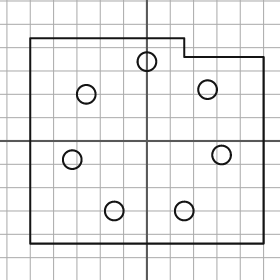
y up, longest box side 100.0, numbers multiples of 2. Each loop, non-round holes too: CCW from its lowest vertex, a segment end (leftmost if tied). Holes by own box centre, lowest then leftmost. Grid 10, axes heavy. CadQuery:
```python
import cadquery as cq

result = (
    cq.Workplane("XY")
    .moveTo(-50.0, -44.0)
    .lineTo(50.0, -44.0)
    .lineTo(50.0, 36.0)
    .lineTo(16.0, 36.0)
    .lineTo(16.0, 44.0)
    .lineTo(-50.0, 44.0)
    .close()
    .moveTo(-14.0, -30.0)
    .circle(4.0)
    .moveTo(16.0, -30.0)
    .circle(4.0)
    .moveTo(-32.0, -8.0)
    .circle(4.0)
    .moveTo(32.0, -6.0)
    .circle(4.0)
    .moveTo(-26.0, 20.0)
    .circle(4.0)
    .moveTo(26.0, 22.0)
    .circle(4.0)
    .moveTo(0.0, 34.0)
    .circle(4.0)
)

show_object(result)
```